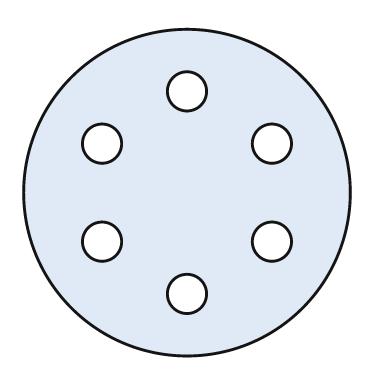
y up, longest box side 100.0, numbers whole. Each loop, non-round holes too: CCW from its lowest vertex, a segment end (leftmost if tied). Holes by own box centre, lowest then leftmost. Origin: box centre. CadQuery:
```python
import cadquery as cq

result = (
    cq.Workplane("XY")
    .moveTo(0.0, 0.0)
    .circle(50.0)
    .moveTo(0.0, -31.0)
    .circle(6.0)
    .moveTo(-26.0, -15.0)
    .circle(6.0)
    .moveTo(26.0, -15.0)
    .circle(6.0)
    .moveTo(-26.0, 15.0)
    .circle(6.0)
    .moveTo(26.0, 15.0)
    .circle(6.0)
    .moveTo(0.0, 31.0)
    .circle(6.0)
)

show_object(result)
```